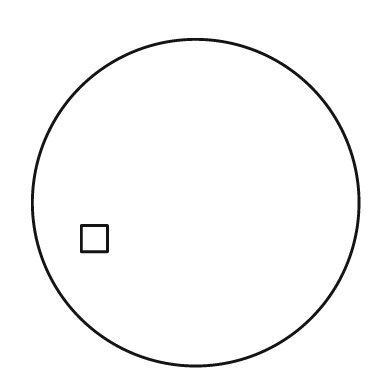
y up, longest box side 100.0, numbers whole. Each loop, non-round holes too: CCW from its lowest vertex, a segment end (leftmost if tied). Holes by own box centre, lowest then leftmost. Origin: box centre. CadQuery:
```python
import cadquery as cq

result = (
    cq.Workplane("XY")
    .moveTo(0.0, 0.0)
    .circle(50.0)
    .moveTo(-35.0, -15.0)
    .lineTo(-27.0, -15.0)
    .lineTo(-27.0, -7.0)
    .lineTo(-35.0, -7.0)
    .close()
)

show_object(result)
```